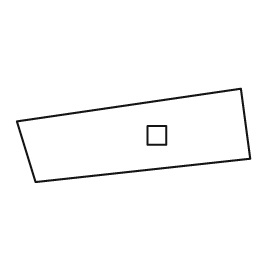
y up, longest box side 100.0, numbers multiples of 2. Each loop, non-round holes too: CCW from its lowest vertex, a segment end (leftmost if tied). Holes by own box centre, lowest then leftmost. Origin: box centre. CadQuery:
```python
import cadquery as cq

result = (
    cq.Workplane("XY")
    .moveTo(-42.0, -20.0)
    .lineTo(50.0, -10.0)
    .lineTo(46.0, 20.0)
    .lineTo(-50.0, 6.0)
    .close()
    .moveTo(6.0, -4.0)
    .lineTo(14.0, -4.0)
    .lineTo(14.0, 4.0)
    .lineTo(6.0, 4.0)
    .close()
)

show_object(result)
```